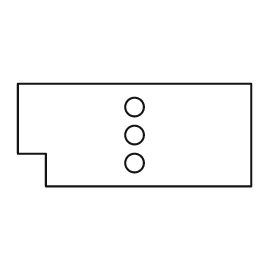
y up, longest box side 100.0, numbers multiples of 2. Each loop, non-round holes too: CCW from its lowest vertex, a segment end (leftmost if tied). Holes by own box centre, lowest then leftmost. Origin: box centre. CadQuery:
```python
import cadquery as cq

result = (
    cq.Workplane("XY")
    .moveTo(-38.0, -22.0)
    .lineTo(50.0, -22.0)
    .lineTo(50.0, 22.0)
    .lineTo(-50.0, 22.0)
    .lineTo(-50.0, -8.0)
    .lineTo(-38.0, -8.0)
    .close()
    .moveTo(0.0, -12.0)
    .circle(4.0)
    .moveTo(0.0, 0.0)
    .circle(4.0)
    .moveTo(0.0, 12.0)
    .circle(4.0)
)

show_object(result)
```